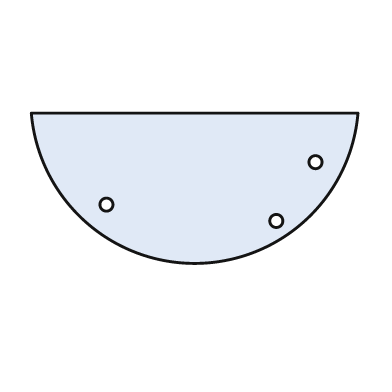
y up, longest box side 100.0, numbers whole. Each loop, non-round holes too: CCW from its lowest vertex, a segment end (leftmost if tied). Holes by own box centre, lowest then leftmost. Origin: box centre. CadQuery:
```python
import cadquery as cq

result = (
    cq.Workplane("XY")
    .moveTo(-50.0, 23.0)
    .threePointArc((0.0, -23.0), (50.0, 23.0))
    .close()
    .moveTo(25.0, -10.0)
    .circle(2.0)
    .moveTo(-27.0, -5.0)
    .circle(2.0)
    .moveTo(37.0, 8.0)
    .circle(2.0)
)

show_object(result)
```